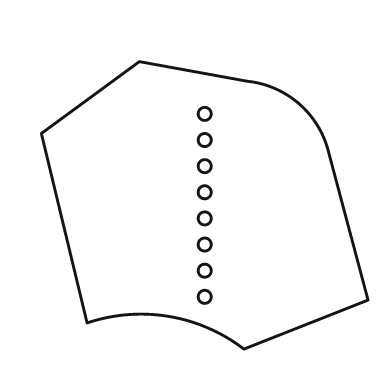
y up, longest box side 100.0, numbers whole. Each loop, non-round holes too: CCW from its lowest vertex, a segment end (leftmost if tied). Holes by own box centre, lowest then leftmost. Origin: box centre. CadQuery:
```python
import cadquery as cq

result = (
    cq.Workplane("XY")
    .moveTo(12.0, -44.0)
    .lineTo(50.0, -29.0)
    .lineTo(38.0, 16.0)
    .threePointArc((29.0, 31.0), (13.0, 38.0))
    .lineTo(-20.0, 44.0)
    .lineTo(-50.0, 22.0)
    .lineTo(-36.0, -36.0)
    .threePointArc((-11.0, -34.0), (12.0, -44.0))
    .close()
    .moveTo(0.0, -28.0)
    .circle(2.0)
    .moveTo(0.0, -20.0)
    .circle(2.0)
    .moveTo(0.0, -12.0)
    .circle(2.0)
    .moveTo(0.0, -4.0)
    .circle(2.0)
    .moveTo(0.0, 4.0)
    .circle(2.0)
    .moveTo(0.0, 12.0)
    .circle(2.0)
    .moveTo(0.0, 20.0)
    .circle(2.0)
    .moveTo(0.0, 28.0)
    .circle(2.0)
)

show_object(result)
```